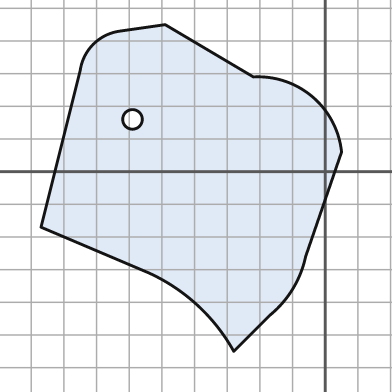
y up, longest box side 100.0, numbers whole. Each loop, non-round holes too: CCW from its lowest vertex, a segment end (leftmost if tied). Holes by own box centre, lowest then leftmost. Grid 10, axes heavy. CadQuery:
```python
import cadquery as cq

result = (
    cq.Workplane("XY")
    .moveTo(-28.0, -55.0)
    .lineTo(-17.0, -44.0)
    .threePointArc((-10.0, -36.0), (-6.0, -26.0))
    .lineTo(5.0, 6.0)
    .threePointArc((-4.0, 23.0), (-22.0, 29.0))
    .lineTo(-49.0, 45.0)
    .lineTo(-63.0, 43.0)
    .threePointArc((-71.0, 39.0), (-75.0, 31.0))
    .lineTo(-87.0, -17.0)
    .lineTo(-54.0, -31.0)
    .threePointArc((-39.0, -41.0), (-28.0, -55.0))
    .close()
    .moveTo(-59.0, 16.0)
    .circle(3.0)
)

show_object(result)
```